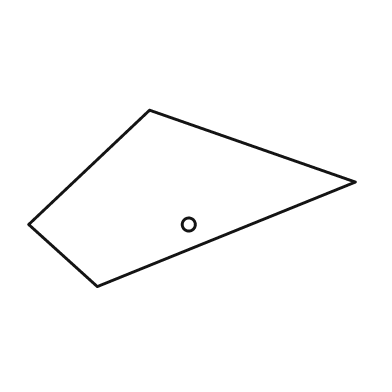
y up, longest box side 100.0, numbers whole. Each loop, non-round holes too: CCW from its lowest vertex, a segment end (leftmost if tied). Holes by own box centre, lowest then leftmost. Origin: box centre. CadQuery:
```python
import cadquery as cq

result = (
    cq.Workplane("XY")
    .moveTo(-29.0, -27.0)
    .lineTo(50.0, 5.0)
    .lineTo(-13.0, 27.0)
    .lineTo(-50.0, -8.0)
    .close()
    .moveTo(-1.0, -8.0)
    .circle(2.0)
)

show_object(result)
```